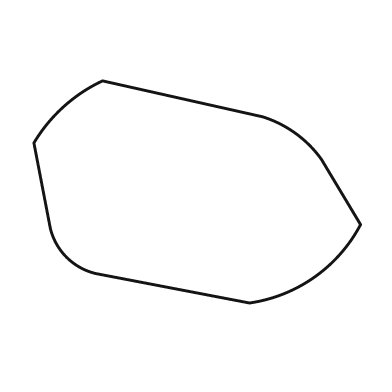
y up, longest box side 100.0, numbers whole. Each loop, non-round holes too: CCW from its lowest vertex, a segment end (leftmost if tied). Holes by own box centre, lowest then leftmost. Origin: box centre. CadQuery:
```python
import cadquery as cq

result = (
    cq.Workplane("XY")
    .moveTo(16.0, -34.0)
    .threePointArc((36.0, -26.0), (50.0, -10.0))
    .lineTo(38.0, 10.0)
    .threePointArc((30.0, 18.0), (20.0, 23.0))
    .lineTo(-29.0, 34.0)
    .threePointArc((-41.0, 26.0), (-50.0, 15.0))
    .lineTo(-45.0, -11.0)
    .threePointArc((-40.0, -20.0), (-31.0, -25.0))
    .close()
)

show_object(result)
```